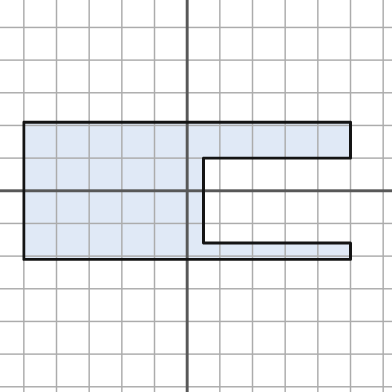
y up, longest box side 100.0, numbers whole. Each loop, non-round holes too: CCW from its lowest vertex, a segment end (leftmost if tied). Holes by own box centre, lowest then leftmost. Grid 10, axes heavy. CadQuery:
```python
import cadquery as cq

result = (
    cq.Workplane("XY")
    .moveTo(-50.0, -21.0)
    .lineTo(50.0, -21.0)
    .lineTo(50.0, -16.0)
    .lineTo(5.0, -16.0)
    .lineTo(5.0, 10.0)
    .lineTo(50.0, 10.0)
    .lineTo(50.0, 21.0)
    .lineTo(-50.0, 21.0)
    .close()
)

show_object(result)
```